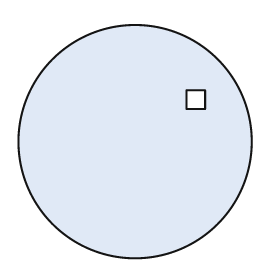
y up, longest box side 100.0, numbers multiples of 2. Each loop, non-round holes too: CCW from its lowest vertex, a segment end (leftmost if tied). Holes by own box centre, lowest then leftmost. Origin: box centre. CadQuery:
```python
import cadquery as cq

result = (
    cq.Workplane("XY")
    .moveTo(0.0, 0.0)
    .circle(50.0)
    .moveTo(22.0, 14.0)
    .lineTo(30.0, 14.0)
    .lineTo(30.0, 22.0)
    .lineTo(22.0, 22.0)
    .close()
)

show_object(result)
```